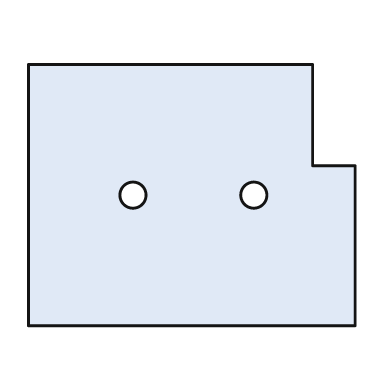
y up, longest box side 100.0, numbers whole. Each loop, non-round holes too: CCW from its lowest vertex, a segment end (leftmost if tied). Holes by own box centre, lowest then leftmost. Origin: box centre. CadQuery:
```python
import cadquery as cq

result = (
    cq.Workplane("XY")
    .moveTo(-50.0, -40.0)
    .lineTo(50.0, -40.0)
    .lineTo(50.0, 9.0)
    .lineTo(37.0, 9.0)
    .lineTo(37.0, 40.0)
    .lineTo(-50.0, 40.0)
    .close()
    .moveTo(-18.0, 0.0)
    .circle(4.0)
    .moveTo(19.0, 0.0)
    .circle(4.0)
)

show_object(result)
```